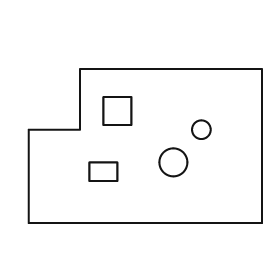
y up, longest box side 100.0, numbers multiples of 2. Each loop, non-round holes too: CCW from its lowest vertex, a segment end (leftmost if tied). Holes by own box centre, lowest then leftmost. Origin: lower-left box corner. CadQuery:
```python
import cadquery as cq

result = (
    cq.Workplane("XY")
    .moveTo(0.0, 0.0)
    .lineTo(100.0, 0.0)
    .lineTo(100.0, 66.0)
    .lineTo(22.0, 66.0)
    .lineTo(22.0, 40.0)
    .lineTo(0.0, 40.0)
    .close()
    .moveTo(26.0, 18.0)
    .lineTo(38.0, 18.0)
    .lineTo(38.0, 26.0)
    .lineTo(26.0, 26.0)
    .close()
    .moveTo(62.0, 26.0)
    .circle(6.0)
    .moveTo(74.0, 40.0)
    .circle(4.0)
    .moveTo(32.0, 42.0)
    .lineTo(44.0, 42.0)
    .lineTo(44.0, 54.0)
    .lineTo(32.0, 54.0)
    .close()
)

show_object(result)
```